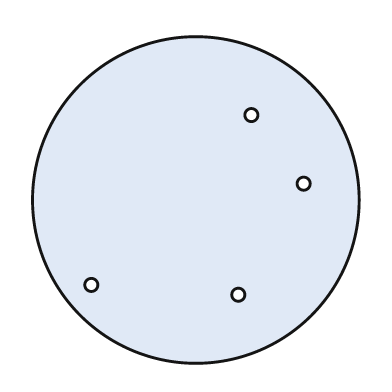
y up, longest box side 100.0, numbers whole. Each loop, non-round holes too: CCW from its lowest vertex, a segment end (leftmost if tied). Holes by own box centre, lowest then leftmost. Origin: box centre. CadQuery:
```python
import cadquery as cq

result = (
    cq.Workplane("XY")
    .moveTo(0.0, 0.0)
    .circle(50.0)
    .moveTo(13.0, -29.0)
    .circle(2.0)
    .moveTo(-32.0, -26.0)
    .circle(2.0)
    .moveTo(33.0, 5.0)
    .circle(2.0)
    .moveTo(17.0, 26.0)
    .circle(2.0)
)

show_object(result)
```